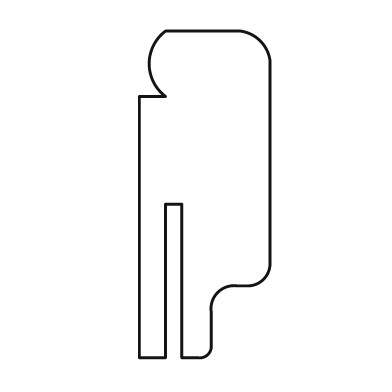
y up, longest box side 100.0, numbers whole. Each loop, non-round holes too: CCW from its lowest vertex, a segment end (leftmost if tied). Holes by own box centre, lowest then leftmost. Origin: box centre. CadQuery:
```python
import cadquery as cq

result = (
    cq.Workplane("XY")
    .moveTo(-20.0, -50.0)
    .lineTo(-12.0, -50.0)
    .lineTo(-12.0, -3.0)
    .lineTo(-7.0, -3.0)
    .lineTo(-7.0, -50.0)
    .lineTo(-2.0, -50.0)
    .threePointArc((1.0, -49.0), (2.0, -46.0))
    .lineTo(2.0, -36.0)
    .threePointArc((4.0, -30.0), (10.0, -28.0))
    .lineTo(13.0, -28.0)
    .threePointArc((18.0, -26.0), (20.0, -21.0))
    .lineTo(20.0, 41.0)
    .threePointArc((17.0, 47.0), (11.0, 50.0))
    .lineTo(-12.0, 50.0)
    .threePointArc((-17.0, 40.0), (-12.0, 30.0))
    .lineTo(-20.0, 30.0)
    .close()
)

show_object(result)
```